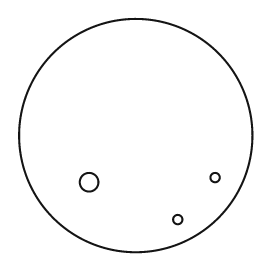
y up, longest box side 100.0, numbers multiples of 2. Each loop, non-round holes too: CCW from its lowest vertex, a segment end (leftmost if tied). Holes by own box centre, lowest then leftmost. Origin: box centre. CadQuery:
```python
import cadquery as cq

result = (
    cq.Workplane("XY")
    .moveTo(0.0, 0.0)
    .circle(50.0)
    .moveTo(18.0, -36.0)
    .circle(2.0)
    .moveTo(-20.0, -20.0)
    .circle(4.0)
    .moveTo(34.0, -18.0)
    .circle(2.0)
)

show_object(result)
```